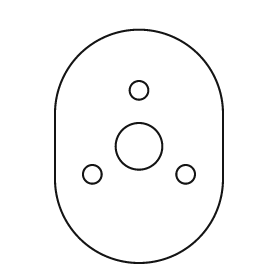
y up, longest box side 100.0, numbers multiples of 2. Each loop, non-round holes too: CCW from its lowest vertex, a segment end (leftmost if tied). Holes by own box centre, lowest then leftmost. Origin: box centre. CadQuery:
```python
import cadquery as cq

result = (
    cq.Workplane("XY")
    .moveTo(-36.0, -14.0)
    .threePointArc((0.0, -50.0), (36.0, -14.0))
    .lineTo(36.0, 14.0)
    .threePointArc((0.0, 50.0), (-36.0, 14.0))
    .close()
    .moveTo(-20.0, -12.0)
    .circle(4.0)
    .moveTo(20.0, -12.0)
    .circle(4.0)
    .moveTo(0.0, 0.0)
    .circle(10.0)
    .moveTo(0.0, 24.0)
    .circle(4.0)
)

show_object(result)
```